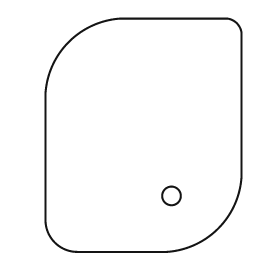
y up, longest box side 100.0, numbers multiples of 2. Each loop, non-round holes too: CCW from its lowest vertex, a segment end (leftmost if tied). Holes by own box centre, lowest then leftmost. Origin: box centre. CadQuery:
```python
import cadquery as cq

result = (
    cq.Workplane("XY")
    .moveTo(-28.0, -50.0)
    .lineTo(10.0, -50.0)
    .threePointArc((32.0, -40.0), (42.0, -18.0))
    .lineTo(42.0, 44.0)
    .threePointArc((40.0, 48.0), (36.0, 50.0))
    .lineTo(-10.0, 50.0)
    .threePointArc((-32.0, 40.0), (-42.0, 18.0))
    .lineTo(-42.0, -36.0)
    .threePointArc((-38.0, -46.0), (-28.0, -50.0))
    .close()
    .moveTo(12.0, -26.0)
    .circle(4.0)
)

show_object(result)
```